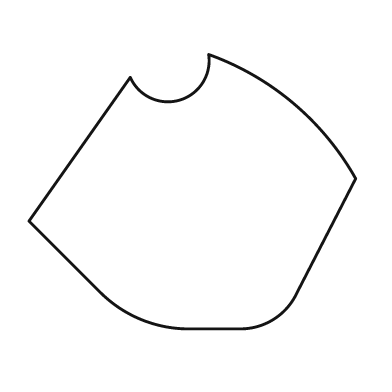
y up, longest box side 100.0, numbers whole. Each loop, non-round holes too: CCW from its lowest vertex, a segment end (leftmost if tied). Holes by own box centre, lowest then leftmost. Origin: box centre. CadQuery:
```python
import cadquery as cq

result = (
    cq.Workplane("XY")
    .moveTo(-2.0, -42.0)
    .lineTo(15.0, -42.0)
    .threePointArc((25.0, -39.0), (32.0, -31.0))
    .lineTo(50.0, 4.0)
    .threePointArc((31.0, 27.0), (5.0, 42.0))
    .threePointArc((-4.0, 28.0), (-19.0, 35.0))
    .lineTo(-50.0, -9.0)
    .lineTo(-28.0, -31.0)
    .threePointArc((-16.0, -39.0), (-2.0, -42.0))
    .close()
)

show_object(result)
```